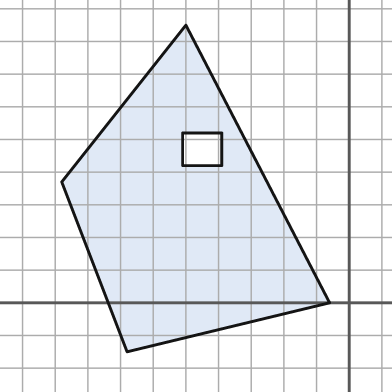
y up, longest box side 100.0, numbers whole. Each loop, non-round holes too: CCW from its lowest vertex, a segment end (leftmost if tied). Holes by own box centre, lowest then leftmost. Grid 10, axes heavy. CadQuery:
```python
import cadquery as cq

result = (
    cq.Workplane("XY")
    .moveTo(-68.0, -15.0)
    .lineTo(-6.0, 0.0)
    .lineTo(-50.0, 85.0)
    .lineTo(-88.0, 37.0)
    .close()
    .moveTo(-51.0, 42.0)
    .lineTo(-39.0, 42.0)
    .lineTo(-39.0, 52.0)
    .lineTo(-51.0, 52.0)
    .close()
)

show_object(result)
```